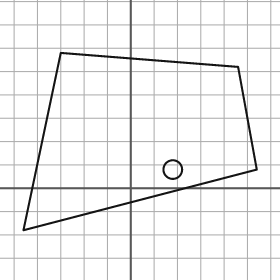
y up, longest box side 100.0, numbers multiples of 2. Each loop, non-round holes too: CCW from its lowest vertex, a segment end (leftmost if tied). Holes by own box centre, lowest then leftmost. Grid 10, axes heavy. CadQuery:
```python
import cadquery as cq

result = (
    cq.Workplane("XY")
    .moveTo(-46.0, -18.0)
    .lineTo(54.0, 8.0)
    .lineTo(46.0, 52.0)
    .lineTo(-30.0, 58.0)
    .close()
    .moveTo(18.0, 8.0)
    .circle(4.0)
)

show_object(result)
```